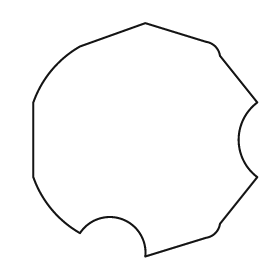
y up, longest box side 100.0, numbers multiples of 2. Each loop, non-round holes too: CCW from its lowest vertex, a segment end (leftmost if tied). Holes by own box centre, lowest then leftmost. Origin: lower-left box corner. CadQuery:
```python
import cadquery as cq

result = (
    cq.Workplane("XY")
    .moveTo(48.0, 0.0)
    .lineTo(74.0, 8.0)
    .threePointArc((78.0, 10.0), (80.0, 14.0))
    .lineTo(96.0, 34.0)
    .threePointArc((88.0, 50.0), (96.0, 66.0))
    .lineTo(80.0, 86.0)
    .threePointArc((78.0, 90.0), (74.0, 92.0))
    .lineTo(48.0, 100.0)
    .lineTo(20.0, 90.0)
    .threePointArc((8.0, 80.0), (0.0, 66.0))
    .lineTo(0.0, 34.0)
    .threePointArc((8.0, 20.0), (20.0, 10.0))
    .threePointArc((38.0, 16.0), (48.0, 0.0))
    .close()
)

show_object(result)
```